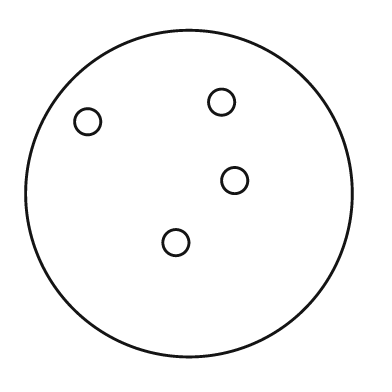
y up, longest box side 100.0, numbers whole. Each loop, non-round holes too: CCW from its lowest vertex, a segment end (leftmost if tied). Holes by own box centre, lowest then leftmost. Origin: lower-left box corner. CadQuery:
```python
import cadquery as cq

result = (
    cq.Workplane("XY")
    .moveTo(50.0, 50.0)
    .circle(50.0)
    .moveTo(46.0, 35.0)
    .circle(4.0)
    .moveTo(64.0, 54.0)
    .circle(4.0)
    .moveTo(19.0, 72.0)
    .circle(4.0)
    .moveTo(60.0, 78.0)
    .circle(4.0)
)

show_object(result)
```